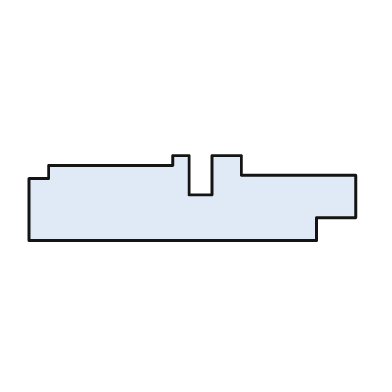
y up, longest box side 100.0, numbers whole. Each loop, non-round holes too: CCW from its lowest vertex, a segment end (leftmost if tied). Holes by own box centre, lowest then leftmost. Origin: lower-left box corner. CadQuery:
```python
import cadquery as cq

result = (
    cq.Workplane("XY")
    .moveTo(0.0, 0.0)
    .lineTo(88.0, 0.0)
    .lineTo(88.0, 7.0)
    .lineTo(100.0, 7.0)
    .lineTo(100.0, 20.0)
    .lineTo(65.0, 20.0)
    .lineTo(65.0, 26.0)
    .lineTo(56.0, 26.0)
    .lineTo(56.0, 14.0)
    .lineTo(49.0, 14.0)
    .lineTo(49.0, 26.0)
    .lineTo(44.0, 26.0)
    .lineTo(44.0, 23.0)
    .lineTo(6.0, 23.0)
    .lineTo(6.0, 19.0)
    .lineTo(0.0, 19.0)
    .close()
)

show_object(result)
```